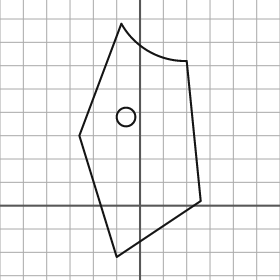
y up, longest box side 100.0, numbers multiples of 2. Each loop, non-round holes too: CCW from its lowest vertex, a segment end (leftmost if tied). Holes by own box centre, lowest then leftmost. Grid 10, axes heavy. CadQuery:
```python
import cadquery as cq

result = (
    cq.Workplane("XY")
    .moveTo(-10.0, -22.0)
    .lineTo(26.0, 2.0)
    .lineTo(20.0, 62.0)
    .threePointArc((4.0, 66.0), (-8.0, 78.0))
    .lineTo(-26.0, 30.0)
    .close()
    .moveTo(-6.0, 38.0)
    .circle(4.0)
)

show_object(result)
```